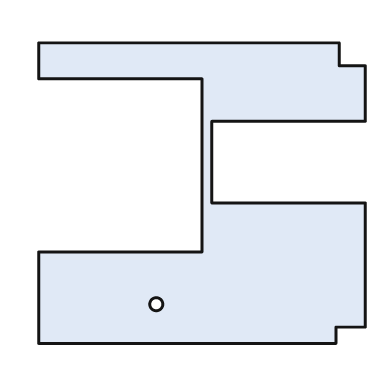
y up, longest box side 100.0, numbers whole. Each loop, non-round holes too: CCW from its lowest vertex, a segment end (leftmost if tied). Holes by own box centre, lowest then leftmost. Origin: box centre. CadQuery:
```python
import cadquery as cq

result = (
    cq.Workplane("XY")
    .moveTo(-50.0, -46.0)
    .lineTo(41.0, -46.0)
    .lineTo(41.0, -41.0)
    .lineTo(50.0, -41.0)
    .lineTo(50.0, -3.0)
    .lineTo(3.0, -3.0)
    .lineTo(3.0, 22.0)
    .lineTo(50.0, 22.0)
    .lineTo(50.0, 39.0)
    .lineTo(42.0, 39.0)
    .lineTo(42.0, 46.0)
    .lineTo(-50.0, 46.0)
    .lineTo(-50.0, 35.0)
    .lineTo(0.0, 35.0)
    .lineTo(0.0, -18.0)
    .lineTo(-50.0, -18.0)
    .close()
    .moveTo(-14.0, -34.0)
    .circle(2.0)
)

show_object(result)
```